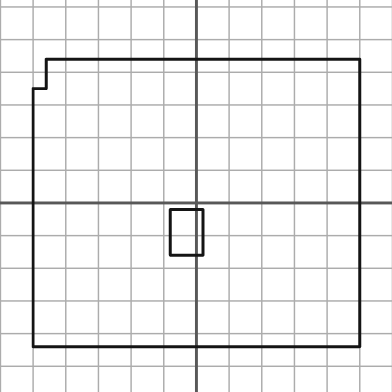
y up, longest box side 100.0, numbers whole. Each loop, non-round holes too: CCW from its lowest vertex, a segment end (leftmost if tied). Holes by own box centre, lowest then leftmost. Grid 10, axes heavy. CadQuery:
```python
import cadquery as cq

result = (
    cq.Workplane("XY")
    .moveTo(-50.0, -44.0)
    .lineTo(50.0, -44.0)
    .lineTo(50.0, 44.0)
    .lineTo(-46.0, 44.0)
    .lineTo(-46.0, 35.0)
    .lineTo(-50.0, 35.0)
    .close()
    .moveTo(-8.0, -16.0)
    .lineTo(2.0, -16.0)
    .lineTo(2.0, -2.0)
    .lineTo(-8.0, -2.0)
    .close()
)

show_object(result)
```